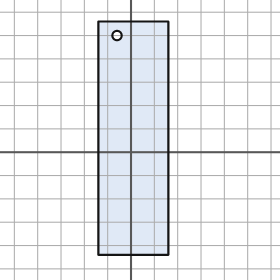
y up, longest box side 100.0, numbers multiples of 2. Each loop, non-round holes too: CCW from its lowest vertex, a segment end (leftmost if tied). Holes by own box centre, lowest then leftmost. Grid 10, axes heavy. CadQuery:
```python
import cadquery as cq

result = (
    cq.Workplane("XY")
    .moveTo(-14.0, -44.0)
    .lineTo(16.0, -44.0)
    .lineTo(16.0, 56.0)
    .lineTo(-14.0, 56.0)
    .close()
    .moveTo(-6.0, 50.0)
    .circle(2.0)
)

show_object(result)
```